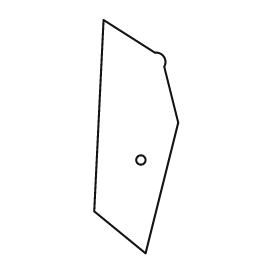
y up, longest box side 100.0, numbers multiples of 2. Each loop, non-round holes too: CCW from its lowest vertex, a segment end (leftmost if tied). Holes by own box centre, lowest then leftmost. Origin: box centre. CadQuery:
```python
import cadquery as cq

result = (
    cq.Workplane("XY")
    .moveTo(4.0, -50.0)
    .lineTo(18.0, 6.0)
    .lineTo(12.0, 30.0)
    .threePointArc((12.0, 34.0), (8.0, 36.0))
    .lineTo(-14.0, 50.0)
    .lineTo(-18.0, -32.0)
    .close()
    .moveTo(2.0, -10.0)
    .circle(2.0)
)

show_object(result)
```